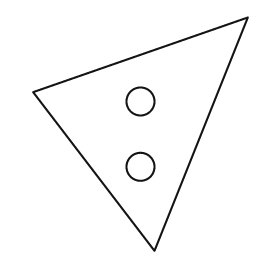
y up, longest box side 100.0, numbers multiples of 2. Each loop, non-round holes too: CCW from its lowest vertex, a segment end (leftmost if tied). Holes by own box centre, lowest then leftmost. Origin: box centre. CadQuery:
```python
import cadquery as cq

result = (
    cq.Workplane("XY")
    .moveTo(6.0, -50.0)
    .lineTo(46.0, 50.0)
    .lineTo(-46.0, 18.0)
    .close()
    .moveTo(0.0, -14.0)
    .circle(6.0)
    .moveTo(0.0, 14.0)
    .circle(6.0)
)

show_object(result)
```